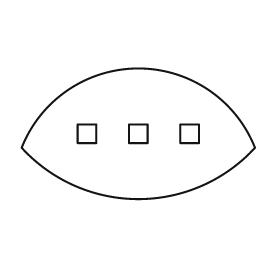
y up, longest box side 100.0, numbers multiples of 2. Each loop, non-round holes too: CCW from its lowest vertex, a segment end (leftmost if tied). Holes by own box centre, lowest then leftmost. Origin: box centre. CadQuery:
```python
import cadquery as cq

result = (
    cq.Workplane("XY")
    .moveTo(-50.0, -6.0)
    .threePointArc((0.0, -28.0), (50.0, -6.0))
    .threePointArc((0.0, 28.0), (-50.0, -6.0))
    .close()
    .moveTo(-26.0, -4.0)
    .lineTo(-18.0, -4.0)
    .lineTo(-18.0, 4.0)
    .lineTo(-26.0, 4.0)
    .close()
    .moveTo(-4.0, -4.0)
    .lineTo(4.0, -4.0)
    .lineTo(4.0, 4.0)
    .lineTo(-4.0, 4.0)
    .close()
    .moveTo(18.0, -4.0)
    .lineTo(26.0, -4.0)
    .lineTo(26.0, 4.0)
    .lineTo(18.0, 4.0)
    .close()
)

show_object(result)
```